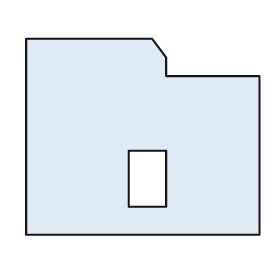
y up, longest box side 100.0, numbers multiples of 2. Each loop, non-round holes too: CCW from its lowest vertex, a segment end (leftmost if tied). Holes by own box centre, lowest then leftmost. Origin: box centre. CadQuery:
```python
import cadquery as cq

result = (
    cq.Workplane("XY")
    .moveTo(-50.0, -42.0)
    .lineTo(50.0, -42.0)
    .lineTo(50.0, 26.0)
    .lineTo(10.0, 26.0)
    .lineTo(10.0, 34.0)
    .lineTo(4.0, 42.0)
    .lineTo(-50.0, 42.0)
    .close()
    .moveTo(-6.0, -30.0)
    .lineTo(10.0, -30.0)
    .lineTo(10.0, -6.0)
    .lineTo(-6.0, -6.0)
    .close()
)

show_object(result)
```